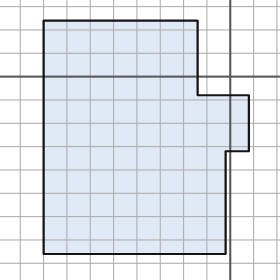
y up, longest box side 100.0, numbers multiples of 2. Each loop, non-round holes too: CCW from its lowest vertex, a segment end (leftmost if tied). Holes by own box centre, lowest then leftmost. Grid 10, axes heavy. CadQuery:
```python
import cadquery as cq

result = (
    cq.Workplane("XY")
    .moveTo(-80.0, -76.0)
    .lineTo(-2.0, -76.0)
    .lineTo(-2.0, -32.0)
    .lineTo(8.0, -32.0)
    .lineTo(8.0, -8.0)
    .lineTo(-14.0, -8.0)
    .lineTo(-14.0, 24.0)
    .lineTo(-80.0, 24.0)
    .close()
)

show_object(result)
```